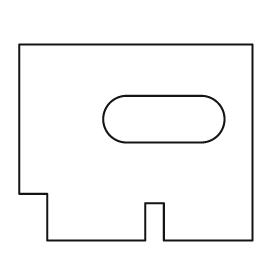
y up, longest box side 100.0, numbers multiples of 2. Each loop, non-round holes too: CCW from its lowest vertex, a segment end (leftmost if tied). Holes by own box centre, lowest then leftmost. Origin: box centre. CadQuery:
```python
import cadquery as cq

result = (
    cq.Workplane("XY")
    .moveTo(-38.0, -42.0)
    .lineTo(4.0, -42.0)
    .lineTo(4.0, -26.0)
    .lineTo(12.0, -26.0)
    .lineTo(12.0, -42.0)
    .lineTo(50.0, -42.0)
    .lineTo(50.0, 42.0)
    .lineTo(-50.0, 42.0)
    .lineTo(-50.0, -22.0)
    .lineTo(-38.0, -22.0)
    .close()
    .moveTo(-4.0, 0.0)
    .lineTo(28.0, 0.0)
    .threePointArc((38.0, 10.0), (28.0, 20.0))
    .lineTo(-4.0, 20.0)
    .threePointArc((-14.0, 10.0), (-4.0, 0.0))
    .close()
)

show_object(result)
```